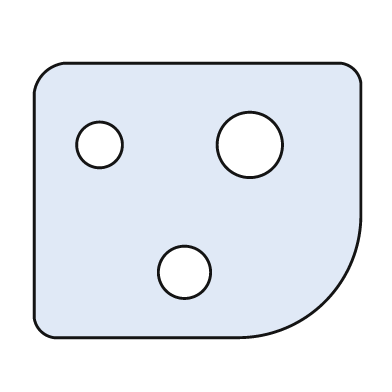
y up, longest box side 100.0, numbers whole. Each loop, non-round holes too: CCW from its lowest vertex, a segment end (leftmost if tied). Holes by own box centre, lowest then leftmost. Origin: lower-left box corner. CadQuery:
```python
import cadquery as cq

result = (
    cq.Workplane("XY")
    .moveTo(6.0, 0.0)
    .lineTo(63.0, 0.0)
    .threePointArc((89.0, 11.0), (100.0, 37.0))
    .lineTo(100.0, 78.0)
    .threePointArc((98.0, 82.0), (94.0, 84.0))
    .lineTo(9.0, 84.0)
    .threePointArc((3.0, 81.0), (0.0, 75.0))
    .lineTo(0.0, 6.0)
    .threePointArc((2.0, 2.0), (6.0, 0.0))
    .close()
    .moveTo(46.0, 20.0)
    .circle(8.0)
    .moveTo(20.0, 59.0)
    .circle(7.0)
    .moveTo(66.0, 59.0)
    .circle(10.0)
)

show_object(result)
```